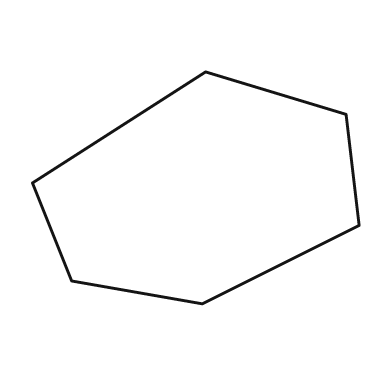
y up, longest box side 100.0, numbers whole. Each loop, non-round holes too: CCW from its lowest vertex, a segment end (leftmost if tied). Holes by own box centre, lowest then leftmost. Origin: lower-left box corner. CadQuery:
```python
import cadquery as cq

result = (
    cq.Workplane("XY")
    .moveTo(52.0, 0.0)
    .lineTo(100.0, 24.0)
    .lineTo(96.0, 58.0)
    .lineTo(53.0, 71.0)
    .lineTo(0.0, 37.0)
    .lineTo(12.0, 7.0)
    .close()
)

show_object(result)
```